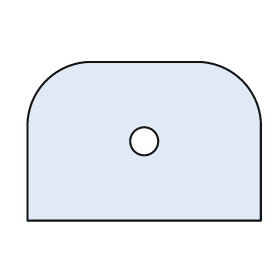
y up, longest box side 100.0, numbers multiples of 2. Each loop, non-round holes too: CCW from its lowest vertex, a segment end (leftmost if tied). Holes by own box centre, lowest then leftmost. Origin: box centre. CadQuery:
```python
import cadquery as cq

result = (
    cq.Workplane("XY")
    .moveTo(-50.0, -34.0)
    .lineTo(50.0, -34.0)
    .lineTo(50.0, 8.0)
    .threePointArc((42.0, 26.0), (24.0, 34.0))
    .lineTo(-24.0, 34.0)
    .threePointArc((-42.0, 26.0), (-50.0, 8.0))
    .close()
    .moveTo(0.0, 0.0)
    .circle(6.0)
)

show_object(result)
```